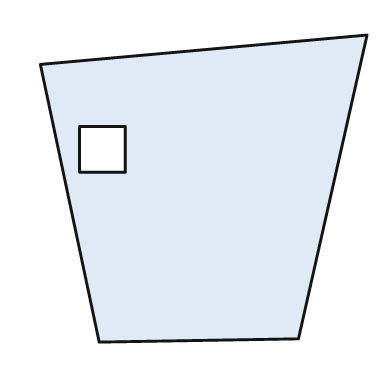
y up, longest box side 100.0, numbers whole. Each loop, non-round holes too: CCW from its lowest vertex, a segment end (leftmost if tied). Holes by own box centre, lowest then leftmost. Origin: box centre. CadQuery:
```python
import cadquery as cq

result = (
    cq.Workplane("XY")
    .moveTo(-32.0, -47.0)
    .lineTo(29.0, -46.0)
    .lineTo(50.0, 47.0)
    .lineTo(-50.0, 38.0)
    .close()
    .moveTo(-38.0, 5.0)
    .lineTo(-24.0, 5.0)
    .lineTo(-24.0, 19.0)
    .lineTo(-38.0, 19.0)
    .close()
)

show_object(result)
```